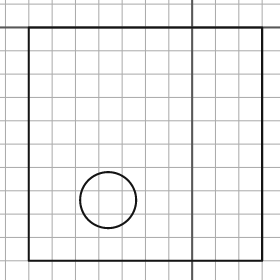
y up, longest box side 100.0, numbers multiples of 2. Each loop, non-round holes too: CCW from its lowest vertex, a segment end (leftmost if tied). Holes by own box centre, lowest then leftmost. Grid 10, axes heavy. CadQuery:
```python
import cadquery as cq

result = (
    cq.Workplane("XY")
    .moveTo(-70.0, -100.0)
    .lineTo(30.0, -100.0)
    .lineTo(30.0, 0.0)
    .lineTo(-70.0, 0.0)
    .close()
    .moveTo(-36.0, -74.0)
    .circle(12.0)
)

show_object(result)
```